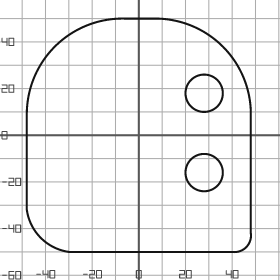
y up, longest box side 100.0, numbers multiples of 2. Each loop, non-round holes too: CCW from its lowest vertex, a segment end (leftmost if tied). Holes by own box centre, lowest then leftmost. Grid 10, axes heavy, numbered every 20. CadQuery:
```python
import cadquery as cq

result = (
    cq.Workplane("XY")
    .moveTo(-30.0, -50.0)
    .lineTo(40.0, -50.0)
    .threePointArc((46.0, -48.0), (48.0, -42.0))
    .lineTo(48.0, 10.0)
    .threePointArc((36.0, 38.0), (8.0, 50.0))
    .lineTo(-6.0, 50.0)
    .threePointArc((-36.0, 38.0), (-48.0, 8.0))
    .lineTo(-48.0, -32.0)
    .threePointArc((-42.0, -44.0), (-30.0, -50.0))
    .close()
    .moveTo(28.0, -16.0)
    .circle(8.0)
    .moveTo(28.0, 18.0)
    .circle(8.0)
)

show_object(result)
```